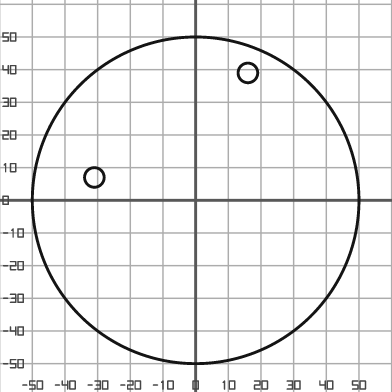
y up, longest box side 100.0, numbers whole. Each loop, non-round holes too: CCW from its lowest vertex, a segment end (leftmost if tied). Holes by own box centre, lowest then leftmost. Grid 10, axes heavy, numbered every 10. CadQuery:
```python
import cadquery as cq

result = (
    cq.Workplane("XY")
    .moveTo(0.0, 0.0)
    .circle(50.0)
    .moveTo(-31.0, 7.0)
    .circle(3.0)
    .moveTo(16.0, 39.0)
    .circle(3.0)
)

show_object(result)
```